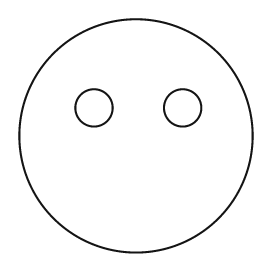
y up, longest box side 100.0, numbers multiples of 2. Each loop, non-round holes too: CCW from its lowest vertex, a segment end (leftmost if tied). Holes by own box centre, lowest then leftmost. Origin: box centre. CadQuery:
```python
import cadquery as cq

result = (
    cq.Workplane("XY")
    .moveTo(0.0, 0.0)
    .circle(50.0)
    .moveTo(-18.0, 12.0)
    .circle(8.0)
    .moveTo(20.0, 12.0)
    .circle(8.0)
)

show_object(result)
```